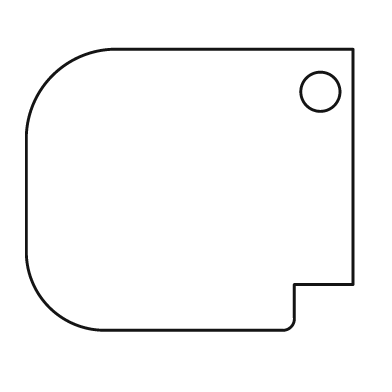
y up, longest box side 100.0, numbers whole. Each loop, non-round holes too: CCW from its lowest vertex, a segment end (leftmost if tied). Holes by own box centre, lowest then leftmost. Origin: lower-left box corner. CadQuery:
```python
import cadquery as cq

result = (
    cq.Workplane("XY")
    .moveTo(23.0, 0.0)
    .lineTo(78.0, 0.0)
    .threePointArc((81.0, 1.0), (82.0, 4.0))
    .lineTo(82.0, 14.0)
    .lineTo(100.0, 14.0)
    .lineTo(100.0, 86.0)
    .lineTo(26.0, 86.0)
    .threePointArc((8.0, 78.0), (0.0, 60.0))
    .lineTo(0.0, 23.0)
    .threePointArc((7.0, 7.0), (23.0, 0.0))
    .close()
    .moveTo(90.0, 73.0)
    .circle(6.0)
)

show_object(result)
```